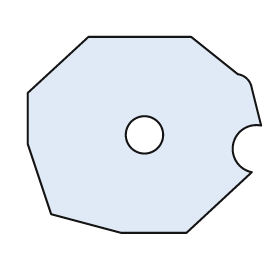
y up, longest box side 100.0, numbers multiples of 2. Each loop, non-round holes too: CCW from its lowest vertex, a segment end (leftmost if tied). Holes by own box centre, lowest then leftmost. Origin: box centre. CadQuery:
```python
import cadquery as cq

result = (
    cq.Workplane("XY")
    .moveTo(-10.0, -42.0)
    .lineTo(18.0, -42.0)
    .lineTo(46.0, -16.0)
    .threePointArc((38.0, -4.0), (50.0, 4.0))
    .lineTo(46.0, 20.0)
    .threePointArc((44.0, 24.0), (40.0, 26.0))
    .lineTo(20.0, 42.0)
    .lineTo(-24.0, 42.0)
    .lineTo(-50.0, 18.0)
    .lineTo(-50.0, -4.0)
    .lineTo(-40.0, -34.0)
    .close()
    .moveTo(0.0, 0.0)
    .circle(8.0)
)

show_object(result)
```